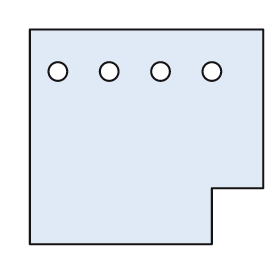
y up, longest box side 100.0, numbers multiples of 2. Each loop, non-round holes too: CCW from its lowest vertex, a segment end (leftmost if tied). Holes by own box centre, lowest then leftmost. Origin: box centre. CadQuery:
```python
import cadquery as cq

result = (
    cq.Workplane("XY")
    .moveTo(-50.0, -46.0)
    .lineTo(28.0, -46.0)
    .lineTo(28.0, -22.0)
    .lineTo(50.0, -22.0)
    .lineTo(50.0, 46.0)
    .lineTo(-50.0, 46.0)
    .close()
    .moveTo(-38.0, 28.0)
    .circle(4.0)
    .moveTo(-16.0, 28.0)
    .circle(4.0)
    .moveTo(6.0, 28.0)
    .circle(4.0)
    .moveTo(28.0, 28.0)
    .circle(4.0)
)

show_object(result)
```